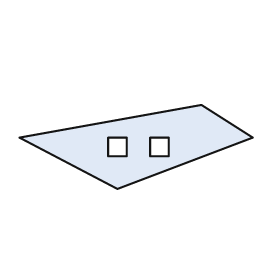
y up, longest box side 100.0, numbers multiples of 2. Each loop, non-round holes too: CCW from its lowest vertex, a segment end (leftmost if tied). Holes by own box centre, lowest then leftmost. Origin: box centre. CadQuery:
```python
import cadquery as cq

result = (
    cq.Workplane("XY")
    .moveTo(-8.0, -18.0)
    .lineTo(50.0, 4.0)
    .lineTo(28.0, 18.0)
    .lineTo(-50.0, 4.0)
    .close()
    .moveTo(-12.0, -4.0)
    .lineTo(-4.0, -4.0)
    .lineTo(-4.0, 4.0)
    .lineTo(-12.0, 4.0)
    .close()
    .moveTo(6.0, -4.0)
    .lineTo(14.0, -4.0)
    .lineTo(14.0, 4.0)
    .lineTo(6.0, 4.0)
    .close()
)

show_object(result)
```